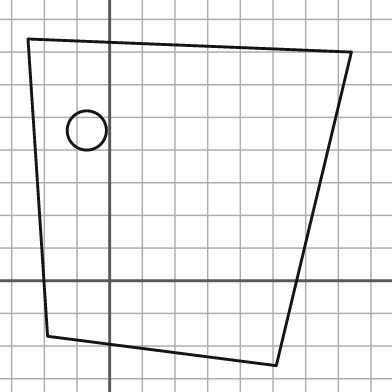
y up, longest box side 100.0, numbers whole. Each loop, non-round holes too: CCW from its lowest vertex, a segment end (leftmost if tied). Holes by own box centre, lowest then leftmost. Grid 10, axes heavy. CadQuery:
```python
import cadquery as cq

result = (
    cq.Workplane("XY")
    .moveTo(51.0, -26.0)
    .lineTo(74.0, 70.0)
    .lineTo(-25.0, 74.0)
    .lineTo(-19.0, -17.0)
    .close()
    .moveTo(-7.0, 46.0)
    .circle(6.0)
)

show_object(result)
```